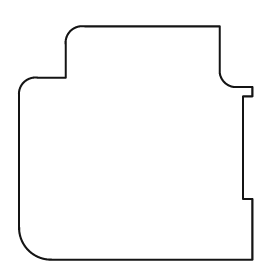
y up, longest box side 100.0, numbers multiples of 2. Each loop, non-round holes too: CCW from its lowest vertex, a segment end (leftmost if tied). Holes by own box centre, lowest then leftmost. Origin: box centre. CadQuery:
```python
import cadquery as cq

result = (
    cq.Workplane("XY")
    .moveTo(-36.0, -50.0)
    .lineTo(50.0, -50.0)
    .lineTo(50.0, -24.0)
    .lineTo(46.0, -24.0)
    .lineTo(46.0, 20.0)
    .lineTo(50.0, 20.0)
    .lineTo(50.0, 24.0)
    .lineTo(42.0, 24.0)
    .threePointArc((38.0, 26.0), (36.0, 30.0))
    .lineTo(36.0, 50.0)
    .lineTo(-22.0, 50.0)
    .threePointArc((-28.0, 48.0), (-30.0, 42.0))
    .lineTo(-30.0, 28.0)
    .lineTo(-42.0, 28.0)
    .threePointArc((-48.0, 26.0), (-50.0, 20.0))
    .lineTo(-50.0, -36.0)
    .threePointArc((-46.0, -46.0), (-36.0, -50.0))
    .close()
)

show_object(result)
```